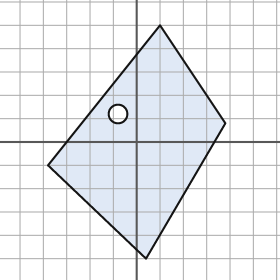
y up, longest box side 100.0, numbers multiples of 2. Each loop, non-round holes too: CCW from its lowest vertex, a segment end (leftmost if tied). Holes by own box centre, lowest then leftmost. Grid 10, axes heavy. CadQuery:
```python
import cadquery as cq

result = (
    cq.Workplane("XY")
    .moveTo(4.0, -50.0)
    .lineTo(38.0, 8.0)
    .lineTo(10.0, 50.0)
    .lineTo(-38.0, -10.0)
    .close()
    .moveTo(-8.0, 12.0)
    .circle(4.0)
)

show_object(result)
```